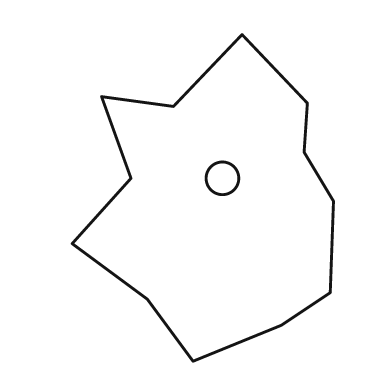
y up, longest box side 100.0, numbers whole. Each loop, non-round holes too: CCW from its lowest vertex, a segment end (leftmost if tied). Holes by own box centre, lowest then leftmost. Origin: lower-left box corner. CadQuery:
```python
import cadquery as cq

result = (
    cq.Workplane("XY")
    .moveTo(37.0, 0.0)
    .lineTo(64.0, 11.0)
    .lineTo(79.0, 21.0)
    .lineTo(80.0, 49.0)
    .lineTo(71.0, 64.0)
    .lineTo(72.0, 79.0)
    .lineTo(52.0, 100.0)
    .lineTo(31.0, 78.0)
    .lineTo(9.0, 81.0)
    .lineTo(18.0, 56.0)
    .lineTo(0.0, 36.0)
    .lineTo(23.0, 19.0)
    .close()
    .moveTo(46.0, 56.0)
    .circle(5.0)
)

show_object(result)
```